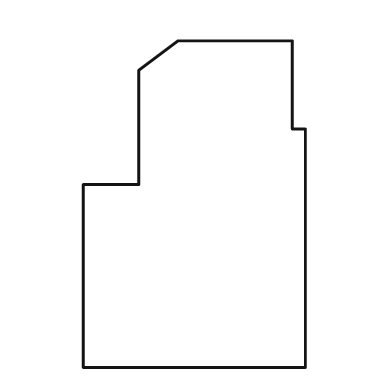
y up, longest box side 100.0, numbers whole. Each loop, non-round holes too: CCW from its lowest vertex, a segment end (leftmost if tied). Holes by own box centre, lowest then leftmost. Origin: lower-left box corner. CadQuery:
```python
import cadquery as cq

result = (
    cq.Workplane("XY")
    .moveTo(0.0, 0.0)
    .lineTo(68.0, 0.0)
    .lineTo(68.0, 73.0)
    .lineTo(64.0, 73.0)
    .lineTo(64.0, 100.0)
    .lineTo(29.0, 100.0)
    .lineTo(17.0, 91.0)
    .lineTo(17.0, 56.0)
    .lineTo(0.0, 56.0)
    .close()
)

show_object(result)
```